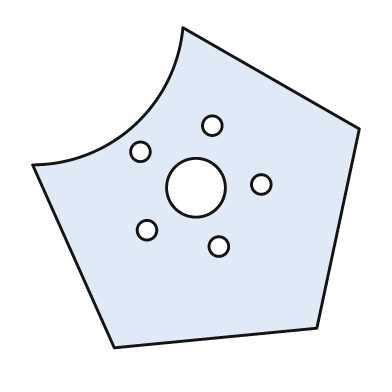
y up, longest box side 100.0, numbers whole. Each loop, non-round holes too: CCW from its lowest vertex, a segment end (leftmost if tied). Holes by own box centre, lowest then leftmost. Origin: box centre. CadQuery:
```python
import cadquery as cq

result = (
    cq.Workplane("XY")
    .moveTo(-25.0, -49.0)
    .lineTo(37.0, -43.0)
    .lineTo(50.0, 18.0)
    .lineTo(-4.0, 49.0)
    .threePointArc((-19.0, 19.0), (-50.0, 7.0))
    .close()
    .moveTo(7.0, -18.0)
    .circle(3.0)
    .moveTo(-15.0, -13.0)
    .circle(3.0)
    .moveTo(0.0, 0.0)
    .circle(9.0)
    .moveTo(20.0, 1.0)
    .circle(3.0)
    .moveTo(-17.0, 11.0)
    .circle(3.0)
    .moveTo(5.0, 19.0)
    .circle(3.0)
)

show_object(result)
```